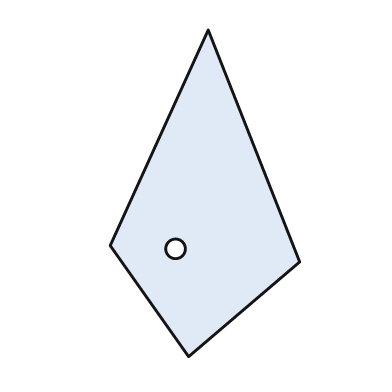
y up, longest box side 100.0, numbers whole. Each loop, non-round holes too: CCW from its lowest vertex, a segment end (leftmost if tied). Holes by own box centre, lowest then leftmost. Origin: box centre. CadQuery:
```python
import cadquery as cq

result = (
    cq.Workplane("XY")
    .moveTo(-5.0, -50.0)
    .lineTo(29.0, -21.0)
    .lineTo(1.0, 50.0)
    .lineTo(-29.0, -16.0)
    .close()
    .moveTo(-9.0, -17.0)
    .circle(3.0)
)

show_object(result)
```